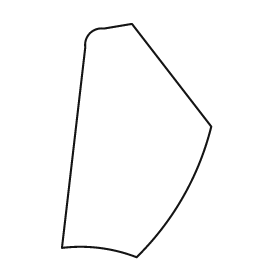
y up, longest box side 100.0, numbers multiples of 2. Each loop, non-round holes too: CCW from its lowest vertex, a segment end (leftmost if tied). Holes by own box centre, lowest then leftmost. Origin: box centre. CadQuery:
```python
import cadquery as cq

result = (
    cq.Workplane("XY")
    .moveTo(0.0, -50.0)
    .threePointArc((20.0, -24.0), (32.0, 6.0))
    .lineTo(-2.0, 50.0)
    .lineTo(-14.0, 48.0)
    .threePointArc((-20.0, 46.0), (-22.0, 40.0))
    .lineTo(-32.0, -46.0)
    .threePointArc((-16.0, -46.0), (0.0, -50.0))
    .close()
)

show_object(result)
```